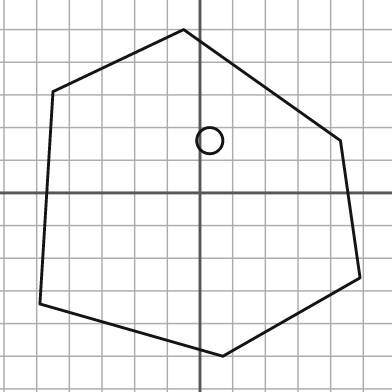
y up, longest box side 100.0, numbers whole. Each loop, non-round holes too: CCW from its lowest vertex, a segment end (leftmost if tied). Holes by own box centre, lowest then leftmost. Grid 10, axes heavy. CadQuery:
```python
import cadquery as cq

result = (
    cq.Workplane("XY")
    .moveTo(7.0, -50.0)
    .lineTo(49.0, -26.0)
    .lineTo(43.0, 16.0)
    .lineTo(-5.0, 50.0)
    .lineTo(-45.0, 31.0)
    .lineTo(-49.0, -34.0)
    .close()
    .moveTo(3.0, 16.0)
    .circle(4.0)
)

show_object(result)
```